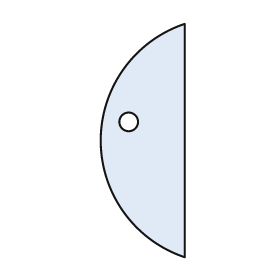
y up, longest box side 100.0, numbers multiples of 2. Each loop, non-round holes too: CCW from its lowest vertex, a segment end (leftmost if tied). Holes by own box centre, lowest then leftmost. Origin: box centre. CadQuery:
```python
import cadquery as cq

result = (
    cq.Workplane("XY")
    .moveTo(18.0, -50.0)
    .lineTo(18.0, 50.0)
    .threePointArc((-18.0, 0.0), (18.0, -50.0))
    .close()
    .moveTo(-6.0, 8.0)
    .circle(4.0)
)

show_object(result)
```